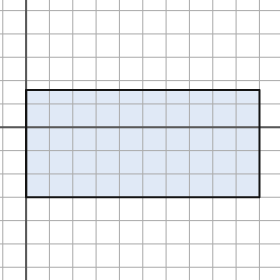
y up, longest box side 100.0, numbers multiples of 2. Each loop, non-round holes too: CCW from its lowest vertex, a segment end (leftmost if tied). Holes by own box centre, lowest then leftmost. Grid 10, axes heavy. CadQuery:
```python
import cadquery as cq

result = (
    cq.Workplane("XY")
    .moveTo(0.0, -30.0)
    .lineTo(100.0, -30.0)
    .lineTo(100.0, 16.0)
    .lineTo(0.0, 16.0)
    .close()
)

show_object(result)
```